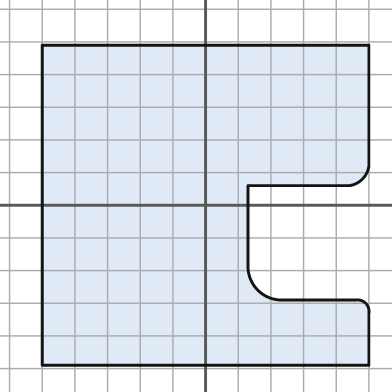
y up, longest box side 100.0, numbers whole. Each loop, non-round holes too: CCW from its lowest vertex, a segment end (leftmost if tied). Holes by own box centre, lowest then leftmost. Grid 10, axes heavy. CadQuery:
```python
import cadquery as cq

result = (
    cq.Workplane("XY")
    .moveTo(-50.0, -49.0)
    .lineTo(50.0, -49.0)
    .lineTo(50.0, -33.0)
    .threePointArc((49.0, -30.0), (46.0, -29.0))
    .lineTo(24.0, -29.0)
    .threePointArc((16.0, -26.0), (13.0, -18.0))
    .lineTo(13.0, 6.0)
    .lineTo(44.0, 6.0)
    .threePointArc((48.0, 8.0), (50.0, 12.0))
    .lineTo(50.0, 49.0)
    .lineTo(-50.0, 49.0)
    .close()
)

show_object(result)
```